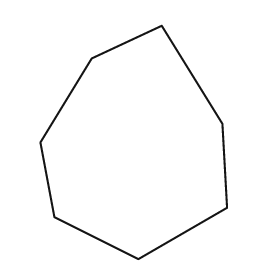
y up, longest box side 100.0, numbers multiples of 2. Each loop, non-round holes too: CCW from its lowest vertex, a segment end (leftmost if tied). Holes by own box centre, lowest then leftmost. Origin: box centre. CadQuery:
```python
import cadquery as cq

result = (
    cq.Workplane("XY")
    .moveTo(2.0, -50.0)
    .lineTo(40.0, -28.0)
    .lineTo(38.0, 8.0)
    .lineTo(12.0, 50.0)
    .lineTo(-18.0, 36.0)
    .lineTo(-40.0, 0.0)
    .lineTo(-34.0, -32.0)
    .close()
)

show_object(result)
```